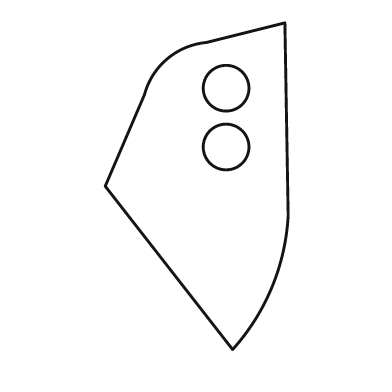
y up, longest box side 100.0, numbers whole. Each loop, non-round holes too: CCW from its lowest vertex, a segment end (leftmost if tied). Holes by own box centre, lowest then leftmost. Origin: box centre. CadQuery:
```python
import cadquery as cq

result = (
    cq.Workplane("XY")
    .moveTo(11.0, -50.0)
    .threePointArc((23.0, -31.0), (28.0, -9.0))
    .lineTo(27.0, 50.0)
    .lineTo(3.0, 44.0)
    .threePointArc((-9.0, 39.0), (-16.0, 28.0))
    .lineTo(-28.0, 0.0)
    .close()
    .moveTo(9.0, 12.0)
    .circle(7.0)
    .moveTo(9.0, 30.0)
    .circle(7.0)
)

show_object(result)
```